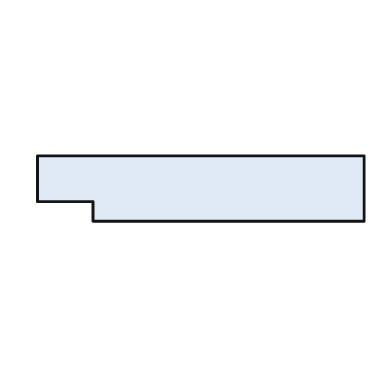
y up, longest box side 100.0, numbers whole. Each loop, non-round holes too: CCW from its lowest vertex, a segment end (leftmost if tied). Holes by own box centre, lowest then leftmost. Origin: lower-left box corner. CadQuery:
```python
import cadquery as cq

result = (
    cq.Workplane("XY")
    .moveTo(17.0, 0.0)
    .lineTo(100.0, 0.0)
    .lineTo(100.0, 20.0)
    .lineTo(0.0, 20.0)
    .lineTo(0.0, 6.0)
    .lineTo(17.0, 6.0)
    .close()
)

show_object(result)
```